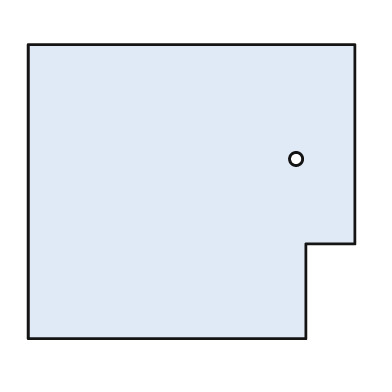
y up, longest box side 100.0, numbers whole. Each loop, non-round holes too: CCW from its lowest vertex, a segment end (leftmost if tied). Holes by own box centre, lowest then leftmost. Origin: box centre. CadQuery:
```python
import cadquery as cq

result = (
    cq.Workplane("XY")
    .moveTo(-50.0, -45.0)
    .lineTo(35.0, -45.0)
    .lineTo(35.0, -16.0)
    .lineTo(50.0, -16.0)
    .lineTo(50.0, 45.0)
    .lineTo(-50.0, 45.0)
    .close()
    .moveTo(32.0, 10.0)
    .circle(2.0)
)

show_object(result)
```